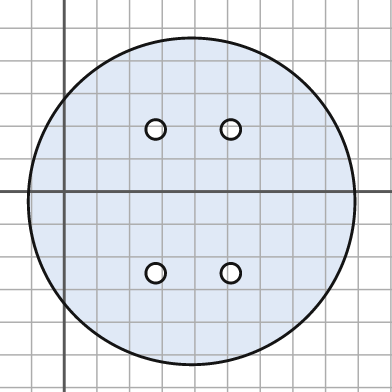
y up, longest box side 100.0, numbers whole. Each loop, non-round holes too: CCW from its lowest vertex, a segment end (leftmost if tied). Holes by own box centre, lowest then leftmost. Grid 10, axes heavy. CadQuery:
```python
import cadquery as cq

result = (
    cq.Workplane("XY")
    .moveTo(39.0, -3.0)
    .circle(50.0)
    .moveTo(28.0, -25.0)
    .circle(3.0)
    .moveTo(51.0, -25.0)
    .circle(3.0)
    .moveTo(28.0, 19.0)
    .circle(3.0)
    .moveTo(51.0, 19.0)
    .circle(3.0)
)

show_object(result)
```